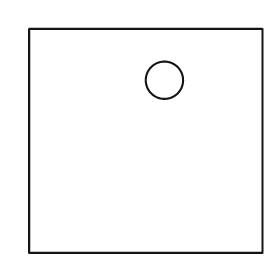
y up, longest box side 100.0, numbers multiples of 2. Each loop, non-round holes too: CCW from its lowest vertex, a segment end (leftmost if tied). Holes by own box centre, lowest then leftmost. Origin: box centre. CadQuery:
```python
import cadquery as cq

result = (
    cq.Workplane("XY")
    .moveTo(-50.0, -48.0)
    .lineTo(50.0, -48.0)
    .lineTo(50.0, 48.0)
    .lineTo(-50.0, 48.0)
    .close()
    .moveTo(8.0, 26.0)
    .circle(8.0)
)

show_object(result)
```